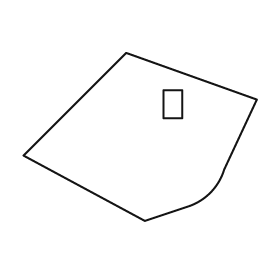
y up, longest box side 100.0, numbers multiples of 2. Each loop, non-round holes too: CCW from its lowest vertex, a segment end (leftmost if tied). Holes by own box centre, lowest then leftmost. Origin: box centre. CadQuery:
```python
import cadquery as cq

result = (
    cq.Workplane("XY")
    .moveTo(2.0, -36.0)
    .lineTo(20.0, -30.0)
    .threePointArc((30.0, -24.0), (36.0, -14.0))
    .lineTo(50.0, 16.0)
    .lineTo(-6.0, 36.0)
    .lineTo(-50.0, -8.0)
    .close()
    .moveTo(10.0, 8.0)
    .lineTo(18.0, 8.0)
    .lineTo(18.0, 20.0)
    .lineTo(10.0, 20.0)
    .close()
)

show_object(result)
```